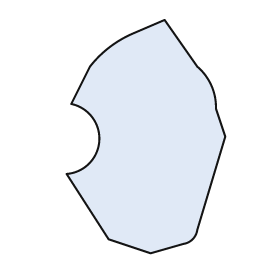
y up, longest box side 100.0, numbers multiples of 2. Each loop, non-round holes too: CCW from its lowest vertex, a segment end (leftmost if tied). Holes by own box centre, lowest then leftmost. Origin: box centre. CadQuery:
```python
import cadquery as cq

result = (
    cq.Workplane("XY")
    .moveTo(2.0, -50.0)
    .lineTo(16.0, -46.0)
    .threePointArc((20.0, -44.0), (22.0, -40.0))
    .lineTo(34.0, 0.0)
    .lineTo(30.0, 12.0)
    .threePointArc((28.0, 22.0), (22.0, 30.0))
    .lineTo(8.0, 50.0)
    .lineTo(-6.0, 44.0)
    .threePointArc((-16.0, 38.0), (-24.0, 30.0))
    .lineTo(-32.0, 14.0)
    .threePointArc((-20.0, -2.0), (-34.0, -16.0))
    .lineTo(-16.0, -44.0)
    .close()
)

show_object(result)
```